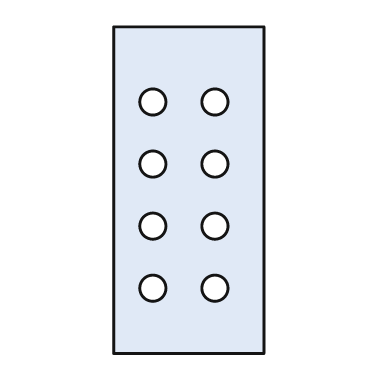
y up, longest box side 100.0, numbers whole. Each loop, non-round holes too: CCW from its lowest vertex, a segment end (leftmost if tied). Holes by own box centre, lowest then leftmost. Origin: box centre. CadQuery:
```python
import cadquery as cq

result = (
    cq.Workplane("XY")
    .moveTo(-23.0, -50.0)
    .lineTo(23.0, -50.0)
    .lineTo(23.0, 50.0)
    .lineTo(-23.0, 50.0)
    .close()
    .moveTo(-11.0, -30.0)
    .circle(4.0)
    .moveTo(8.0, -30.0)
    .circle(4.0)
    .moveTo(-11.0, -11.0)
    .circle(4.0)
    .moveTo(8.0, -11.0)
    .circle(4.0)
    .moveTo(-11.0, 8.0)
    .circle(4.0)
    .moveTo(8.0, 8.0)
    .circle(4.0)
    .moveTo(-11.0, 27.0)
    .circle(4.0)
    .moveTo(8.0, 27.0)
    .circle(4.0)
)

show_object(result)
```